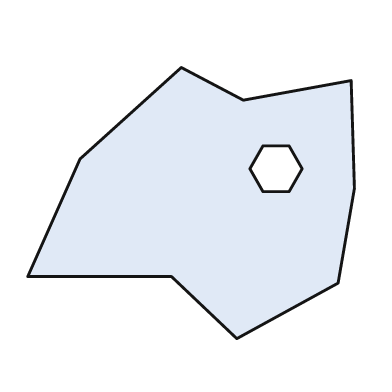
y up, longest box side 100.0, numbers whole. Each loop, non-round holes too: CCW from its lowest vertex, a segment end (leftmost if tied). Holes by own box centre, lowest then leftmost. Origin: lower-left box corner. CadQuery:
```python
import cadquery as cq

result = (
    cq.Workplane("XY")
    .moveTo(64.0, 0.0)
    .lineTo(95.0, 17.0)
    .lineTo(100.0, 46.0)
    .lineTo(99.0, 79.0)
    .lineTo(66.0, 73.0)
    .lineTo(47.0, 83.0)
    .lineTo(16.0, 55.0)
    .lineTo(0.0, 19.0)
    .lineTo(44.0, 19.0)
    .close()
    .moveTo(72.0, 45.0)
    .lineTo(80.0, 45.0)
    .lineTo(84.0, 52.0)
    .lineTo(80.0, 59.0)
    .lineTo(72.0, 59.0)
    .lineTo(68.0, 52.0)
    .close()
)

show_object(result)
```